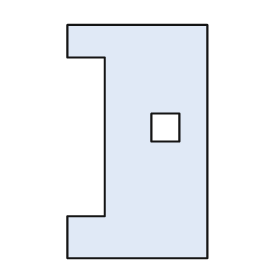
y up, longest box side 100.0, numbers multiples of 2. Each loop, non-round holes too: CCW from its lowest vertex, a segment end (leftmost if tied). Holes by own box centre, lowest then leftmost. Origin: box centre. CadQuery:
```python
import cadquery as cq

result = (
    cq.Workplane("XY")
    .moveTo(-30.0, -50.0)
    .lineTo(30.0, -50.0)
    .lineTo(30.0, 50.0)
    .lineTo(-30.0, 50.0)
    .lineTo(-30.0, 36.0)
    .lineTo(-14.0, 36.0)
    .lineTo(-14.0, -32.0)
    .lineTo(-30.0, -32.0)
    .close()
    .moveTo(6.0, 0.0)
    .lineTo(18.0, 0.0)
    .lineTo(18.0, 12.0)
    .lineTo(6.0, 12.0)
    .close()
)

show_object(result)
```